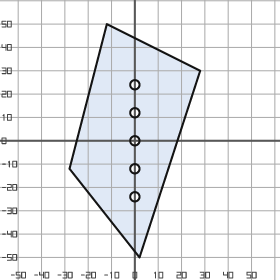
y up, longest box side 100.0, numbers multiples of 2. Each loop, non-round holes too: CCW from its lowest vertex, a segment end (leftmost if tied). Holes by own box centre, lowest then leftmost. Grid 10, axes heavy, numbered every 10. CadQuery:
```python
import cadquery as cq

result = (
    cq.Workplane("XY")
    .moveTo(2.0, -50.0)
    .lineTo(28.0, 30.0)
    .lineTo(-12.0, 50.0)
    .lineTo(-28.0, -12.0)
    .close()
    .moveTo(0.0, -24.0)
    .circle(2.0)
    .moveTo(0.0, -12.0)
    .circle(2.0)
    .moveTo(0.0, 0.0)
    .circle(2.0)
    .moveTo(0.0, 12.0)
    .circle(2.0)
    .moveTo(0.0, 24.0)
    .circle(2.0)
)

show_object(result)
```